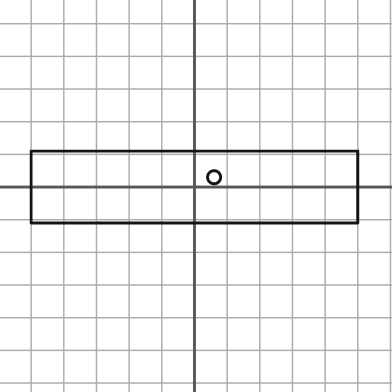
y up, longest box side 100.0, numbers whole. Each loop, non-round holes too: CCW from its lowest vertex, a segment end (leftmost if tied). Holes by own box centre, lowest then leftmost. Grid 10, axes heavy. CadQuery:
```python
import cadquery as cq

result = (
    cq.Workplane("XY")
    .moveTo(-50.0, -11.0)
    .lineTo(50.0, -11.0)
    .lineTo(50.0, 11.0)
    .lineTo(-50.0, 11.0)
    .close()
    .moveTo(6.0, 3.0)
    .circle(2.0)
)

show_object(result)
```